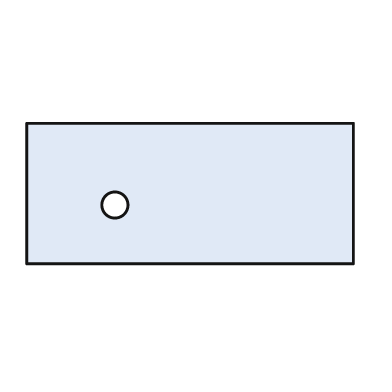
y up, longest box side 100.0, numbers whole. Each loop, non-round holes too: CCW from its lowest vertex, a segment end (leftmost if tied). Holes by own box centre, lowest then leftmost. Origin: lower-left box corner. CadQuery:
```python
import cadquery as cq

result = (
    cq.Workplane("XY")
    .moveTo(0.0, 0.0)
    .lineTo(100.0, 0.0)
    .lineTo(100.0, 43.0)
    .lineTo(0.0, 43.0)
    .close()
    .moveTo(27.0, 18.0)
    .circle(4.0)
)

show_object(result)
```